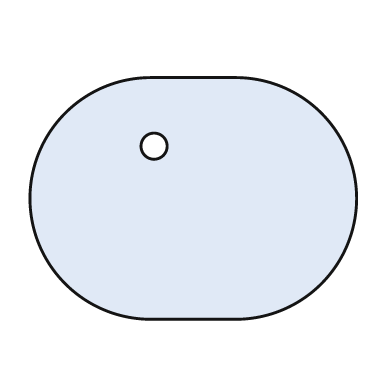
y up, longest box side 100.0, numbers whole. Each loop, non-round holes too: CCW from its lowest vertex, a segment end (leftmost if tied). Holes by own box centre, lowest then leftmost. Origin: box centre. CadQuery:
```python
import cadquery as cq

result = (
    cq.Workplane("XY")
    .moveTo(-13.0, -37.0)
    .lineTo(13.0, -37.0)
    .threePointArc((50.0, 0.0), (13.0, 37.0))
    .lineTo(-13.0, 37.0)
    .threePointArc((-50.0, 0.0), (-13.0, -37.0))
    .close()
    .moveTo(-12.0, 16.0)
    .circle(4.0)
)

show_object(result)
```